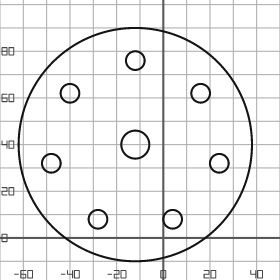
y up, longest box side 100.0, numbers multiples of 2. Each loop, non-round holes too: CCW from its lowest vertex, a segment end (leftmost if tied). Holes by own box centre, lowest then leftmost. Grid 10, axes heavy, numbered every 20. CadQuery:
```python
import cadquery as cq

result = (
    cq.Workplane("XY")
    .moveTo(-12.0, 40.0)
    .circle(50.0)
    .moveTo(-28.0, 8.0)
    .circle(4.0)
    .moveTo(4.0, 8.0)
    .circle(4.0)
    .moveTo(-48.0, 32.0)
    .circle(4.0)
    .moveTo(24.0, 32.0)
    .circle(4.0)
    .moveTo(-12.0, 40.0)
    .circle(6.0)
    .moveTo(-40.0, 62.0)
    .circle(4.0)
    .moveTo(16.0, 62.0)
    .circle(4.0)
    .moveTo(-12.0, 76.0)
    .circle(4.0)
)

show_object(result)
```